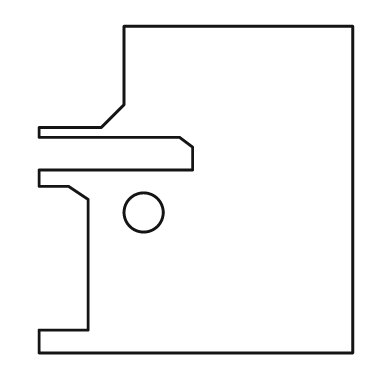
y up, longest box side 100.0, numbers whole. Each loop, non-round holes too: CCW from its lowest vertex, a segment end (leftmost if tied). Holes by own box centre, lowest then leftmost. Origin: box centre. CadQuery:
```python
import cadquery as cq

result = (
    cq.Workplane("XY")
    .moveTo(-48.0, -50.0)
    .lineTo(48.0, -50.0)
    .lineTo(48.0, 50.0)
    .lineTo(-22.0, 50.0)
    .lineTo(-22.0, 26.0)
    .lineTo(-29.0, 19.0)
    .lineTo(-48.0, 19.0)
    .lineTo(-48.0, 16.0)
    .lineTo(-5.0, 16.0)
    .lineTo(-1.0, 13.0)
    .lineTo(-1.0, 6.0)
    .lineTo(-48.0, 6.0)
    .lineTo(-48.0, 1.0)
    .lineTo(-39.0, 1.0)
    .lineTo(-33.0, -3.0)
    .lineTo(-33.0, -43.0)
    .lineTo(-48.0, -43.0)
    .close()
    .moveTo(-16.0, -7.0)
    .circle(6.0)
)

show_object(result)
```